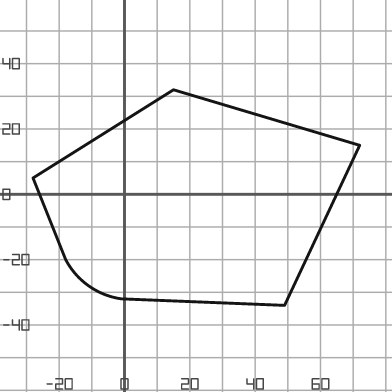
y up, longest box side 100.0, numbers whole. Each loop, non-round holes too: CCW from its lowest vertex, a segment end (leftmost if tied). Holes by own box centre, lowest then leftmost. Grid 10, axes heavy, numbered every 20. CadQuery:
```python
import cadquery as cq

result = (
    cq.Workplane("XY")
    .moveTo(49.0, -34.0)
    .lineTo(72.0, 15.0)
    .lineTo(15.0, 32.0)
    .lineTo(-28.0, 5.0)
    .lineTo(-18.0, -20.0)
    .threePointArc((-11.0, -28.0), (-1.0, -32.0))
    .close()
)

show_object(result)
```